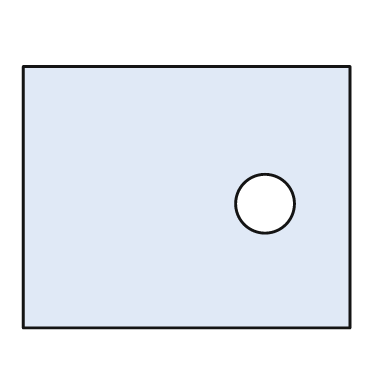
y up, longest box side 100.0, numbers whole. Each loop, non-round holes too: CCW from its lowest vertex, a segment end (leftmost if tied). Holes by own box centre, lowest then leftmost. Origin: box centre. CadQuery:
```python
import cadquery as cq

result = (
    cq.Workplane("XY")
    .moveTo(-50.0, -40.0)
    .lineTo(50.0, -40.0)
    .lineTo(50.0, 40.0)
    .lineTo(-50.0, 40.0)
    .close()
    .moveTo(24.0, -2.0)
    .circle(9.0)
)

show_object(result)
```